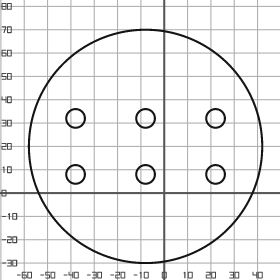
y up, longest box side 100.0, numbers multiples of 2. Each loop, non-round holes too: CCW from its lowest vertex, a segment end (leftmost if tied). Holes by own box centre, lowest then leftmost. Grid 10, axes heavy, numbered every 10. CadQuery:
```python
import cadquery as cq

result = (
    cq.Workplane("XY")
    .moveTo(-8.0, 20.0)
    .circle(50.0)
    .moveTo(-38.0, 8.0)
    .circle(4.0)
    .moveTo(-8.0, 8.0)
    .circle(4.0)
    .moveTo(22.0, 8.0)
    .circle(4.0)
    .moveTo(-38.0, 32.0)
    .circle(4.0)
    .moveTo(-8.0, 32.0)
    .circle(4.0)
    .moveTo(22.0, 32.0)
    .circle(4.0)
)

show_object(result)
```